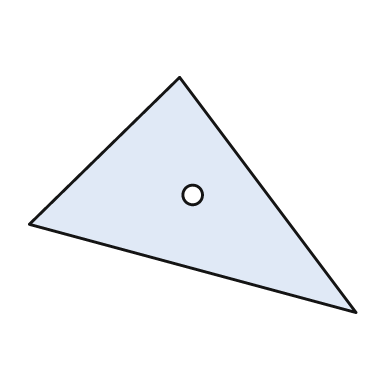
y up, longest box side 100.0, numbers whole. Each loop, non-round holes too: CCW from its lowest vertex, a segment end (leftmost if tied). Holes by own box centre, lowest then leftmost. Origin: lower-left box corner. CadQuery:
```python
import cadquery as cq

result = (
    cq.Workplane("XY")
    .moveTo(100.0, 0.0)
    .lineTo(46.0, 72.0)
    .lineTo(0.0, 27.0)
    .close()
    .moveTo(50.0, 36.0)
    .circle(3.0)
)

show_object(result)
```